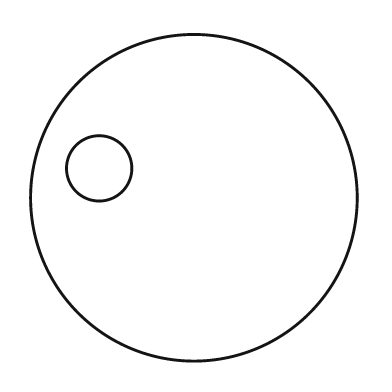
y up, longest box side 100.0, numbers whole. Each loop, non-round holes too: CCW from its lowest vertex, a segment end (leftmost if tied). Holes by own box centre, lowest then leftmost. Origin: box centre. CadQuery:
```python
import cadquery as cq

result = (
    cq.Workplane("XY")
    .moveTo(0.0, 0.0)
    .circle(50.0)
    .moveTo(-29.0, 9.0)
    .circle(10.0)
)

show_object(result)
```